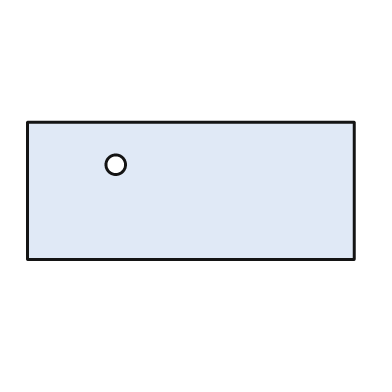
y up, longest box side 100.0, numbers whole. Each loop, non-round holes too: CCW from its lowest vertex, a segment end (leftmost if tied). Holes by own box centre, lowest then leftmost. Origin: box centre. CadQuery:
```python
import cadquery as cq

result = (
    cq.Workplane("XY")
    .moveTo(-50.0, -21.0)
    .lineTo(50.0, -21.0)
    .lineTo(50.0, 21.0)
    .lineTo(-50.0, 21.0)
    .close()
    .moveTo(-23.0, 8.0)
    .circle(3.0)
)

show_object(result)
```